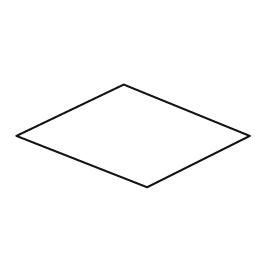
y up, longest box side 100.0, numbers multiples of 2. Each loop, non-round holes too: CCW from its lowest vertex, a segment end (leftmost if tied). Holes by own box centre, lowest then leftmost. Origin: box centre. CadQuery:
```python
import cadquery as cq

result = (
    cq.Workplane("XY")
    .moveTo(6.0, -22.0)
    .lineTo(50.0, 0.0)
    .lineTo(-4.0, 22.0)
    .lineTo(-50.0, 0.0)
    .close()
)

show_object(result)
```